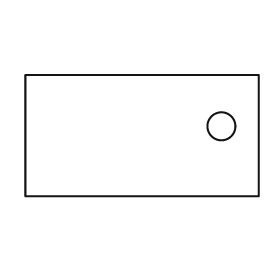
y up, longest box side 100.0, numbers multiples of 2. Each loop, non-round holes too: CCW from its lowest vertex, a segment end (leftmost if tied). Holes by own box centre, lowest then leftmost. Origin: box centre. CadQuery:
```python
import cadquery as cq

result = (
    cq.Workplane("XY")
    .moveTo(-50.0, -26.0)
    .lineTo(50.0, -26.0)
    .lineTo(50.0, 26.0)
    .lineTo(-50.0, 26.0)
    .close()
    .moveTo(34.0, 4.0)
    .circle(6.0)
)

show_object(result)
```